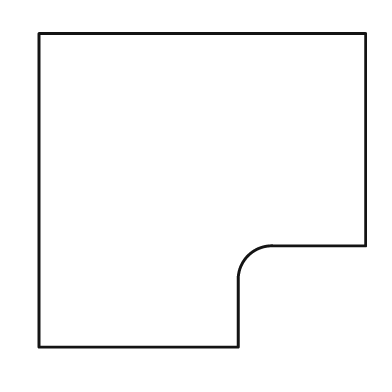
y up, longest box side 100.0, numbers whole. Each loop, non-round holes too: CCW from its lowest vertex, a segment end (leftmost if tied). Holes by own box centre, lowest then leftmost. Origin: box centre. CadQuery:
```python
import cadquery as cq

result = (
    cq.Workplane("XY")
    .moveTo(-50.0, -48.0)
    .lineTo(11.0, -48.0)
    .lineTo(11.0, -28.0)
    .threePointArc((14.0, -20.0), (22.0, -17.0))
    .lineTo(50.0, -17.0)
    .lineTo(50.0, 48.0)
    .lineTo(-50.0, 48.0)
    .close()
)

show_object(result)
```